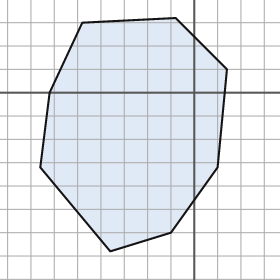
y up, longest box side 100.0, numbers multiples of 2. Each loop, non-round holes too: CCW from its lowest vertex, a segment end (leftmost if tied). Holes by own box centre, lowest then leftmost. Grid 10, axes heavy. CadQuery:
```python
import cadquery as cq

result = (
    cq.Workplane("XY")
    .moveTo(-36.0, -68.0)
    .lineTo(-10.0, -60.0)
    .lineTo(10.0, -32.0)
    .lineTo(14.0, 10.0)
    .lineTo(-8.0, 32.0)
    .lineTo(-48.0, 30.0)
    .lineTo(-62.0, 0.0)
    .lineTo(-66.0, -32.0)
    .close()
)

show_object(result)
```